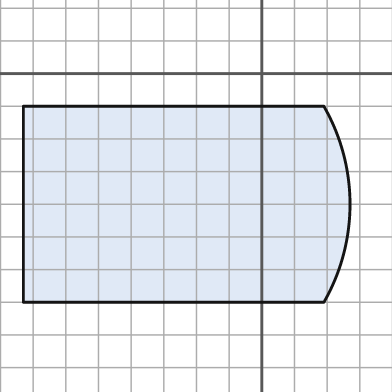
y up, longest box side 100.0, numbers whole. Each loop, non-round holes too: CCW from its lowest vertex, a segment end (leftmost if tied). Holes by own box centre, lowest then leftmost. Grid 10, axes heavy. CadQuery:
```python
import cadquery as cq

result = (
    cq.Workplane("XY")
    .moveTo(-73.0, -70.0)
    .lineTo(19.0, -70.0)
    .threePointArc((27.0, -40.0), (19.0, -10.0))
    .lineTo(-73.0, -10.0)
    .close()
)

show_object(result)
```